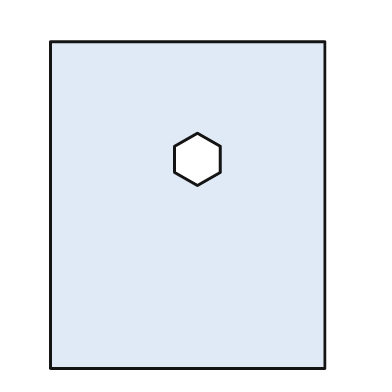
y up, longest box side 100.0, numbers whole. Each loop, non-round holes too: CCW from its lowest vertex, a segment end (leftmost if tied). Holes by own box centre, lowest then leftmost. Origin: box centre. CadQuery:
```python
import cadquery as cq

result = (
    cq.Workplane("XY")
    .moveTo(-42.0, -50.0)
    .lineTo(42.0, -50.0)
    .lineTo(42.0, 50.0)
    .lineTo(-42.0, 50.0)
    .close()
    .moveTo(3.0, 6.0)
    .lineTo(10.0, 10.0)
    .lineTo(10.0, 18.0)
    .lineTo(3.0, 22.0)
    .lineTo(-4.0, 18.0)
    .lineTo(-4.0, 10.0)
    .close()
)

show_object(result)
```